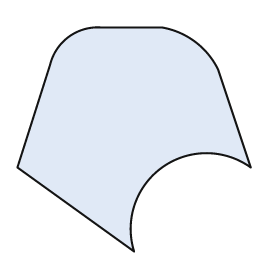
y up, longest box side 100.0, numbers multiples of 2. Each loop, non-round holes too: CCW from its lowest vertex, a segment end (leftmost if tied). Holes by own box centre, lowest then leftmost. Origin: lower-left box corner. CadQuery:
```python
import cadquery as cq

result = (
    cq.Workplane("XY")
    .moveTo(50.0, 0.0)
    .threePointArc((62.0, 36.0), (100.0, 36.0))
    .lineTo(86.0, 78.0)
    .threePointArc((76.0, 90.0), (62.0, 96.0))
    .lineTo(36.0, 96.0)
    .threePointArc((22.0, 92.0), (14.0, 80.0))
    .lineTo(0.0, 36.0)
    .close()
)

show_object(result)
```